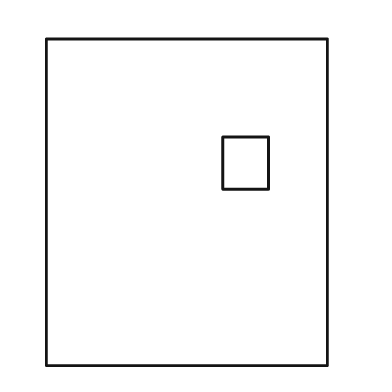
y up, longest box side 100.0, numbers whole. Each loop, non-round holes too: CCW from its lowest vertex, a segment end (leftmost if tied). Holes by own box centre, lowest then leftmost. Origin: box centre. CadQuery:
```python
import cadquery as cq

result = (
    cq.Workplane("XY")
    .moveTo(-43.0, -50.0)
    .lineTo(43.0, -50.0)
    .lineTo(43.0, 50.0)
    .lineTo(-43.0, 50.0)
    .close()
    .moveTo(11.0, 4.0)
    .lineTo(25.0, 4.0)
    .lineTo(25.0, 20.0)
    .lineTo(11.0, 20.0)
    .close()
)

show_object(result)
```